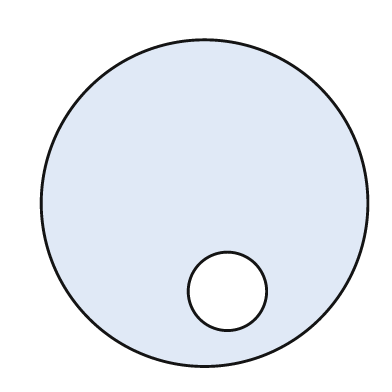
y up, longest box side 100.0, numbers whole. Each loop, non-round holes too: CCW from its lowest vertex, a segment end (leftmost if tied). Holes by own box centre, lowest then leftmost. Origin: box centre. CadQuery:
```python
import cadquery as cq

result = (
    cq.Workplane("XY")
    .moveTo(0.0, 0.0)
    .circle(50.0)
    .moveTo(7.0, -27.0)
    .circle(12.0)
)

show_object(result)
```